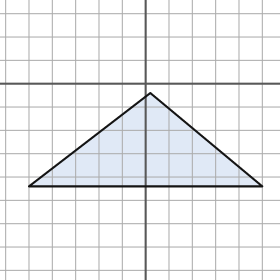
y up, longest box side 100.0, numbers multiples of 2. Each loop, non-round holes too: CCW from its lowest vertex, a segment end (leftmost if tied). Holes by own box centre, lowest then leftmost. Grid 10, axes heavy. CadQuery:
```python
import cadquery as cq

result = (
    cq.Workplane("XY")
    .moveTo(-50.0, -44.0)
    .lineTo(50.0, -44.0)
    .lineTo(2.0, -4.0)
    .close()
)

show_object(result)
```